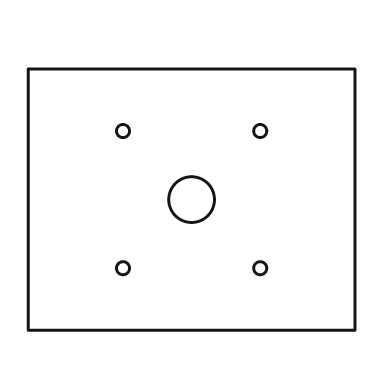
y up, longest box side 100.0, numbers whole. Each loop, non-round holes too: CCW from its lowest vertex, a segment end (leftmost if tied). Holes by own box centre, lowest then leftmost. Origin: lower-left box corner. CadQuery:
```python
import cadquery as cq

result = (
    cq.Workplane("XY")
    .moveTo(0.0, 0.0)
    .lineTo(100.0, 0.0)
    .lineTo(100.0, 80.0)
    .lineTo(0.0, 80.0)
    .close()
    .moveTo(29.0, 19.0)
    .circle(2.0)
    .moveTo(71.0, 19.0)
    .circle(2.0)
    .moveTo(50.0, 40.0)
    .circle(7.0)
    .moveTo(29.0, 61.0)
    .circle(2.0)
    .moveTo(71.0, 61.0)
    .circle(2.0)
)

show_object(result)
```